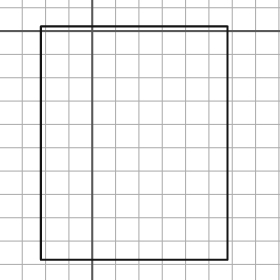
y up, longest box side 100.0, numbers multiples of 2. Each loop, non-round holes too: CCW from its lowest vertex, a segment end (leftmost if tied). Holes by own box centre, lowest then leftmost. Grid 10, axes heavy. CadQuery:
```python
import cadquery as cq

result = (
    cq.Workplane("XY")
    .moveTo(-22.0, -98.0)
    .lineTo(58.0, -98.0)
    .lineTo(58.0, 2.0)
    .lineTo(-22.0, 2.0)
    .close()
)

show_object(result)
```